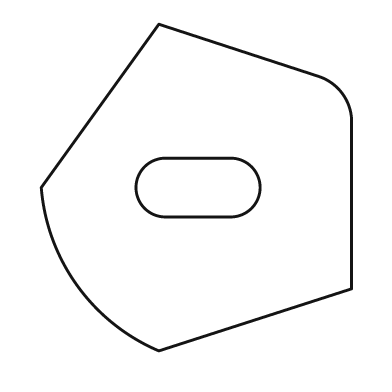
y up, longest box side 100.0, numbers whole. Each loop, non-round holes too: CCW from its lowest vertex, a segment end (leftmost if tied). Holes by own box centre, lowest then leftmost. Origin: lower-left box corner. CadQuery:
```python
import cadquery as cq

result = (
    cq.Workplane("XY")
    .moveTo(36.0, 0.0)
    .lineTo(95.0, 19.0)
    .lineTo(95.0, 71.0)
    .threePointArc((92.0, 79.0), (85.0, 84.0))
    .lineTo(36.0, 100.0)
    .lineTo(0.0, 50.0)
    .threePointArc((11.0, 20.0), (36.0, 0.0))
    .close()
    .moveTo(38.0, 41.0)
    .lineTo(58.0, 41.0)
    .threePointArc((67.0, 50.0), (58.0, 59.0))
    .lineTo(38.0, 59.0)
    .threePointArc((29.0, 50.0), (38.0, 41.0))
    .close()
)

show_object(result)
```